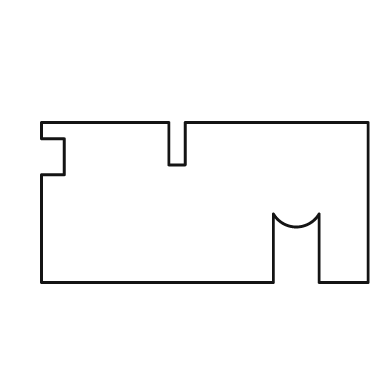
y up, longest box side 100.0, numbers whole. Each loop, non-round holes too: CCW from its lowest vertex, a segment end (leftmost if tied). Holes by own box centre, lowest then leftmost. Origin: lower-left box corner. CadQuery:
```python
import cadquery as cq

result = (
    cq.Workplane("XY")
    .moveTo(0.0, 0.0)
    .lineTo(71.0, 0.0)
    .lineTo(71.0, 21.0)
    .threePointArc((78.0, 17.0), (85.0, 21.0))
    .lineTo(85.0, 0.0)
    .lineTo(100.0, 0.0)
    .lineTo(100.0, 49.0)
    .lineTo(44.0, 49.0)
    .lineTo(44.0, 36.0)
    .lineTo(39.0, 36.0)
    .lineTo(39.0, 49.0)
    .lineTo(0.0, 49.0)
    .lineTo(0.0, 44.0)
    .lineTo(7.0, 44.0)
    .lineTo(7.0, 33.0)
    .lineTo(0.0, 33.0)
    .close()
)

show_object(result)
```